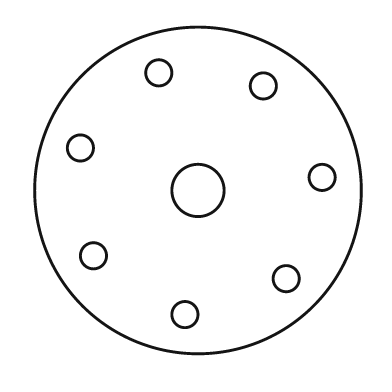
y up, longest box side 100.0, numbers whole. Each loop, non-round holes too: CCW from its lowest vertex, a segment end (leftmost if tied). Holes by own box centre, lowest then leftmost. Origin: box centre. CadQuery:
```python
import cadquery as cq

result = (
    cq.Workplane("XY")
    .moveTo(0.0, 0.0)
    .circle(50.0)
    .moveTo(-4.0, -38.0)
    .circle(4.0)
    .moveTo(27.0, -27.0)
    .circle(4.0)
    .moveTo(-32.0, -20.0)
    .circle(4.0)
    .moveTo(0.0, 0.0)
    .circle(8.0)
    .moveTo(38.0, 4.0)
    .circle(4.0)
    .moveTo(-36.0, 13.0)
    .circle(4.0)
    .moveTo(20.0, 32.0)
    .circle(4.0)
    .moveTo(-12.0, 36.0)
    .circle(4.0)
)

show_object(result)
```